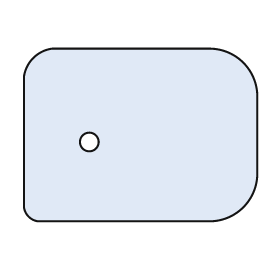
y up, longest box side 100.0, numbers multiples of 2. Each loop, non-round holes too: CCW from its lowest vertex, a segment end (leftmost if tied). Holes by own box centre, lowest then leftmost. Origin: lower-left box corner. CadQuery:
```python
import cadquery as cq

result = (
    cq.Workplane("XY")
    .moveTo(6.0, 0.0)
    .lineTo(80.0, 0.0)
    .threePointArc((94.0, 6.0), (100.0, 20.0))
    .lineTo(100.0, 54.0)
    .threePointArc((94.0, 68.0), (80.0, 74.0))
    .lineTo(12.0, 74.0)
    .threePointArc((4.0, 70.0), (0.0, 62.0))
    .lineTo(0.0, 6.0)
    .threePointArc((2.0, 2.0), (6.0, 0.0))
    .close()
    .moveTo(28.0, 34.0)
    .circle(4.0)
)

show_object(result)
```